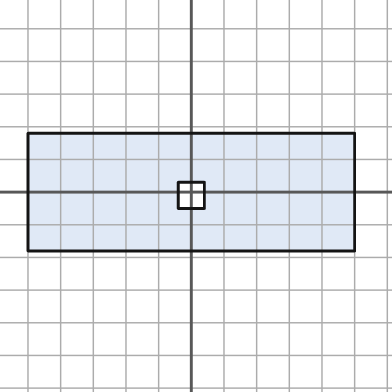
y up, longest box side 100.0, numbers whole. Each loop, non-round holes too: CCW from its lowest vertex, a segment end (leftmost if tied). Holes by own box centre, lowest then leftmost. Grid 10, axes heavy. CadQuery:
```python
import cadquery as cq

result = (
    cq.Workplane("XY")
    .moveTo(-50.0, -18.0)
    .lineTo(50.0, -18.0)
    .lineTo(50.0, 18.0)
    .lineTo(-50.0, 18.0)
    .close()
    .moveTo(-4.0, -5.0)
    .lineTo(4.0, -5.0)
    .lineTo(4.0, 3.0)
    .lineTo(-4.0, 3.0)
    .close()
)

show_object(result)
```